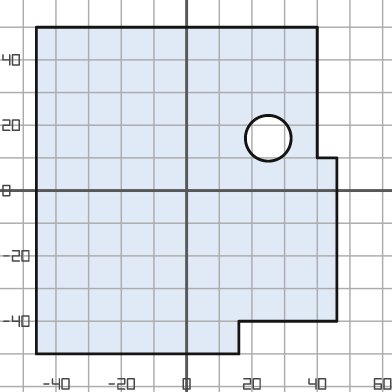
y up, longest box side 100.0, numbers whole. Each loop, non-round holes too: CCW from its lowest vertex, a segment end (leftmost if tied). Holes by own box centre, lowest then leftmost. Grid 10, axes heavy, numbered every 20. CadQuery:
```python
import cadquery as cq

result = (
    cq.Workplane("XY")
    .moveTo(-46.0, -50.0)
    .lineTo(16.0, -50.0)
    .lineTo(16.0, -40.0)
    .lineTo(46.0, -40.0)
    .lineTo(46.0, 10.0)
    .lineTo(40.0, 10.0)
    .lineTo(40.0, 50.0)
    .lineTo(-46.0, 50.0)
    .close()
    .moveTo(25.0, 16.0)
    .circle(7.0)
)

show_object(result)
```